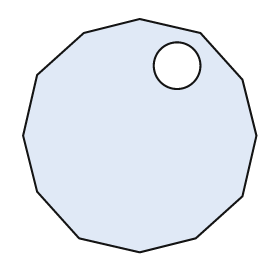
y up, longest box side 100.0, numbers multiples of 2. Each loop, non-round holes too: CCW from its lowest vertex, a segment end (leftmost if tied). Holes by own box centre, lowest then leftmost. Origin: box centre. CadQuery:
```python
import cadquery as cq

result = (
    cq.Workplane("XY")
    .moveTo(0.0, -50.0)
    .lineTo(24.0, -44.0)
    .lineTo(44.0, -26.0)
    .lineTo(50.0, 0.0)
    .lineTo(44.0, 24.0)
    .lineTo(26.0, 44.0)
    .lineTo(0.0, 50.0)
    .lineTo(-24.0, 44.0)
    .lineTo(-44.0, 26.0)
    .lineTo(-50.0, 0.0)
    .lineTo(-44.0, -24.0)
    .lineTo(-26.0, -44.0)
    .close()
    .moveTo(16.0, 30.0)
    .circle(10.0)
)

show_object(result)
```